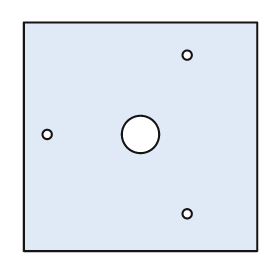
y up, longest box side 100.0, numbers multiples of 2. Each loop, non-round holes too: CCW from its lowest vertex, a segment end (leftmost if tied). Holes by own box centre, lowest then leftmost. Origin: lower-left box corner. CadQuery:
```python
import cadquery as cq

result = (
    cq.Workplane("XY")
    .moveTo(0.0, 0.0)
    .lineTo(100.0, 0.0)
    .lineTo(100.0, 98.0)
    .lineTo(0.0, 98.0)
    .close()
    .moveTo(70.0, 16.0)
    .circle(2.0)
    .moveTo(10.0, 50.0)
    .circle(2.0)
    .moveTo(50.0, 50.0)
    .circle(8.0)
    .moveTo(70.0, 84.0)
    .circle(2.0)
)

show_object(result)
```